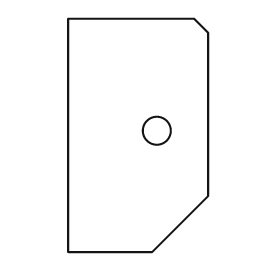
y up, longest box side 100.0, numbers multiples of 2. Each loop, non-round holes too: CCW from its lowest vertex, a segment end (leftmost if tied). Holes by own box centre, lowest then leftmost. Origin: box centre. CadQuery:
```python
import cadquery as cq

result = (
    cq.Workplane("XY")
    .moveTo(-30.0, -50.0)
    .lineTo(6.0, -50.0)
    .lineTo(30.0, -26.0)
    .lineTo(30.0, 44.0)
    .lineTo(24.0, 50.0)
    .lineTo(-30.0, 50.0)
    .close()
    .moveTo(8.0, 2.0)
    .circle(6.0)
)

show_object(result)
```